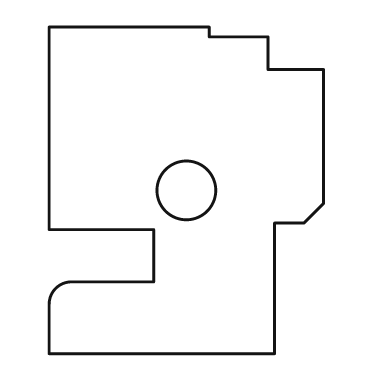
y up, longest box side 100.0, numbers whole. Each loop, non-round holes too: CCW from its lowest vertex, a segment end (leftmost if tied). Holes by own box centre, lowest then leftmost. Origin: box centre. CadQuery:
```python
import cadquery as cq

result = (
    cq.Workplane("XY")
    .moveTo(-42.0, -50.0)
    .lineTo(27.0, -50.0)
    .lineTo(27.0, -10.0)
    .lineTo(36.0, -10.0)
    .lineTo(42.0, -4.0)
    .lineTo(42.0, 37.0)
    .lineTo(25.0, 37.0)
    .lineTo(25.0, 47.0)
    .lineTo(7.0, 47.0)
    .lineTo(7.0, 50.0)
    .lineTo(-42.0, 50.0)
    .lineTo(-42.0, -12.0)
    .lineTo(-10.0, -12.0)
    .lineTo(-10.0, -28.0)
    .lineTo(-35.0, -28.0)
    .threePointArc((-40.0, -30.0), (-42.0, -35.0))
    .close()
    .moveTo(0.0, 0.0)
    .circle(9.0)
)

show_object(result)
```